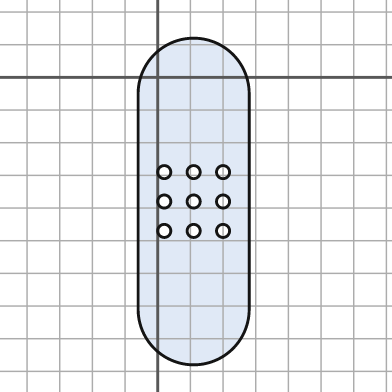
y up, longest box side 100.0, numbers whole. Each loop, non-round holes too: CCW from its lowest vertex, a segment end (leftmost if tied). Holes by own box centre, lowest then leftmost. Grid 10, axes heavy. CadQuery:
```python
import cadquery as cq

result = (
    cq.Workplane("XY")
    .moveTo(-6.0, -71.0)
    .threePointArc((11.0, -88.0), (28.0, -71.0))
    .lineTo(28.0, -5.0)
    .threePointArc((11.0, 12.0), (-6.0, -5.0))
    .close()
    .moveTo(2.0, -47.0)
    .circle(2.0)
    .moveTo(11.0, -47.0)
    .circle(2.0)
    .moveTo(20.0, -47.0)
    .circle(2.0)
    .moveTo(2.0, -38.0)
    .circle(2.0)
    .moveTo(11.0, -38.0)
    .circle(2.0)
    .moveTo(20.0, -38.0)
    .circle(2.0)
    .moveTo(2.0, -29.0)
    .circle(2.0)
    .moveTo(11.0, -29.0)
    .circle(2.0)
    .moveTo(20.0, -29.0)
    .circle(2.0)
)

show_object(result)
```